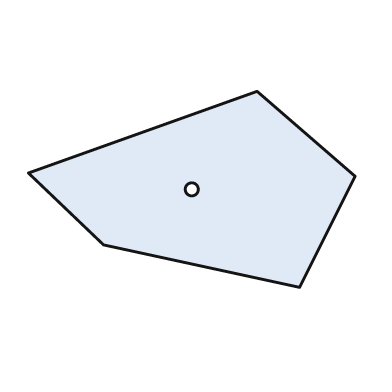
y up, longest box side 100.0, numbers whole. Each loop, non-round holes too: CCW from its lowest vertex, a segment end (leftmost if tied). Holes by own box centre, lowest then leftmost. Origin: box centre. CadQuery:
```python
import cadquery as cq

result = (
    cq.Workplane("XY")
    .moveTo(33.0, -30.0)
    .lineTo(50.0, 4.0)
    .lineTo(20.0, 30.0)
    .lineTo(-50.0, 5.0)
    .lineTo(-27.0, -17.0)
    .close()
    .moveTo(0.0, 0.0)
    .circle(2.0)
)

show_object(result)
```